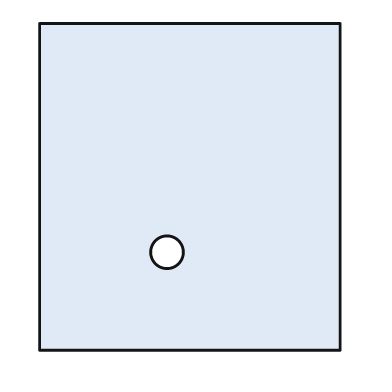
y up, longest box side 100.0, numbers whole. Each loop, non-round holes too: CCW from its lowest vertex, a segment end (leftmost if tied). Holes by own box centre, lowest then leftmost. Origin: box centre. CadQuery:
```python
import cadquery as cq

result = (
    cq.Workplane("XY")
    .moveTo(-46.0, -50.0)
    .lineTo(46.0, -50.0)
    .lineTo(46.0, 50.0)
    .lineTo(-46.0, 50.0)
    .close()
    .moveTo(-7.0, -20.0)
    .circle(5.0)
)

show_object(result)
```